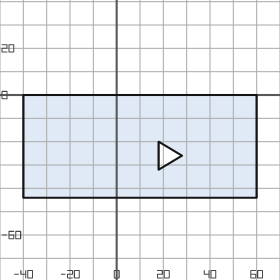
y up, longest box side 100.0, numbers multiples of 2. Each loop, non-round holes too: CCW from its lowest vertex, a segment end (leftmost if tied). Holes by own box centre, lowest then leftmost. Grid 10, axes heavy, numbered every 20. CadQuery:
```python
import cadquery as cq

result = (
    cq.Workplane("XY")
    .moveTo(-40.0, -44.0)
    .lineTo(60.0, -44.0)
    .lineTo(60.0, 0.0)
    .lineTo(-40.0, 0.0)
    .close()
    .moveTo(18.0, -32.0)
    .lineTo(28.0, -26.0)
    .lineTo(18.0, -20.0)
    .close()
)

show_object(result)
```